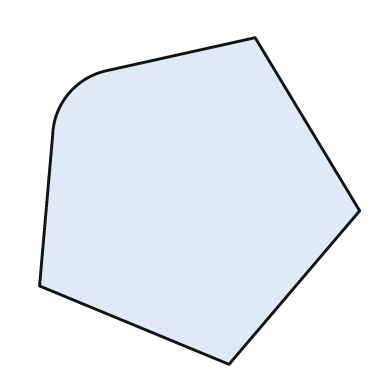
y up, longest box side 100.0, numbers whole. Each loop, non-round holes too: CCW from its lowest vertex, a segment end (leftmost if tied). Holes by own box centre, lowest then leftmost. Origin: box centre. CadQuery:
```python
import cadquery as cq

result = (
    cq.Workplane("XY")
    .moveTo(9.0, -50.0)
    .lineTo(49.0, -3.0)
    .lineTo(17.0, 50.0)
    .lineTo(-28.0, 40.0)
    .threePointArc((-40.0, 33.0), (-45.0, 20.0))
    .lineTo(-49.0, -26.0)
    .close()
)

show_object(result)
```